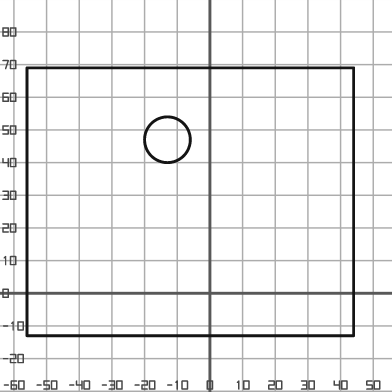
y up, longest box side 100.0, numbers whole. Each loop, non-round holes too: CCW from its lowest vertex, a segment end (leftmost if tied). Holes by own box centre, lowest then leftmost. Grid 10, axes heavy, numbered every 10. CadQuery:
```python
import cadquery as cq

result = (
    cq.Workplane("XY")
    .moveTo(-56.0, -13.0)
    .lineTo(44.0, -13.0)
    .lineTo(44.0, 69.0)
    .lineTo(-56.0, 69.0)
    .close()
    .moveTo(-13.0, 47.0)
    .circle(7.0)
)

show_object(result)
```